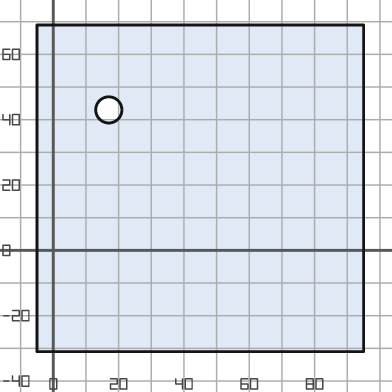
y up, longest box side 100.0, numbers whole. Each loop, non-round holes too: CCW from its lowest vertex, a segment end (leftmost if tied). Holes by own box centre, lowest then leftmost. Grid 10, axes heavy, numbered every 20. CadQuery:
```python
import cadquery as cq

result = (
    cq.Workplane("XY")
    .moveTo(-5.0, -31.0)
    .lineTo(95.0, -31.0)
    .lineTo(95.0, 69.0)
    .lineTo(-5.0, 69.0)
    .close()
    .moveTo(17.0, 43.0)
    .circle(4.0)
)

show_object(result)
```